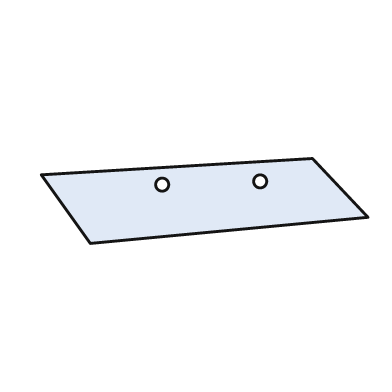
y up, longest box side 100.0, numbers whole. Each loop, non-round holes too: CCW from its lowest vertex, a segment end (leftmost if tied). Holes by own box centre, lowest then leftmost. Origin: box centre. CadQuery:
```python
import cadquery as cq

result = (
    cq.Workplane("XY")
    .moveTo(-35.0, -13.0)
    .lineTo(50.0, -5.0)
    .lineTo(33.0, 13.0)
    .lineTo(-50.0, 8.0)
    .close()
    .moveTo(-13.0, 5.0)
    .circle(2.0)
    .moveTo(17.0, 6.0)
    .circle(2.0)
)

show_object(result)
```